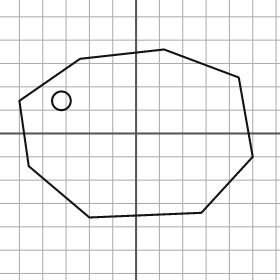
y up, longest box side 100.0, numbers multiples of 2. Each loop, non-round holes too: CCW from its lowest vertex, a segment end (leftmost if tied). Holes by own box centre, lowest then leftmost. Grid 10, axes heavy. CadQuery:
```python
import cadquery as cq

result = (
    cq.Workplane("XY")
    .moveTo(-20.0, -36.0)
    .lineTo(28.0, -34.0)
    .lineTo(50.0, -10.0)
    .lineTo(44.0, 24.0)
    .lineTo(12.0, 36.0)
    .lineTo(-24.0, 32.0)
    .lineTo(-50.0, 14.0)
    .lineTo(-46.0, -14.0)
    .close()
    .moveTo(-32.0, 14.0)
    .circle(4.0)
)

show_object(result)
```